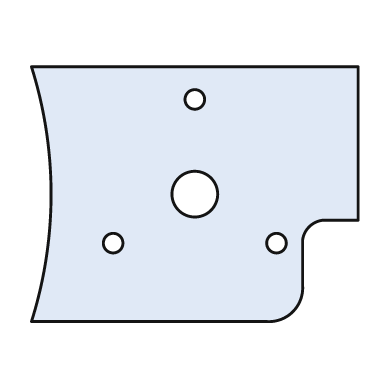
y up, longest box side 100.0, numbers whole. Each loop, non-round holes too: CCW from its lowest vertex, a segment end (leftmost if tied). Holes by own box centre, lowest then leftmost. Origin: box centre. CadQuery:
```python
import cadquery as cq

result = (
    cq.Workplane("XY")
    .moveTo(-50.0, -39.0)
    .lineTo(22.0, -39.0)
    .threePointArc((30.0, -36.0), (33.0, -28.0))
    .lineTo(33.0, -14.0)
    .threePointArc((35.0, -10.0), (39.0, -8.0))
    .lineTo(50.0, -8.0)
    .lineTo(50.0, 39.0)
    .lineTo(-50.0, 39.0)
    .threePointArc((-44.0, 0.0), (-50.0, -39.0))
    .close()
    .moveTo(-25.0, -15.0)
    .circle(3.0)
    .moveTo(25.0, -15.0)
    .circle(3.0)
    .moveTo(0.0, 0.0)
    .circle(7.0)
    .moveTo(0.0, 29.0)
    .circle(3.0)
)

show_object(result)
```